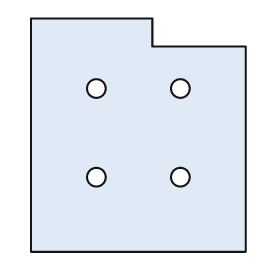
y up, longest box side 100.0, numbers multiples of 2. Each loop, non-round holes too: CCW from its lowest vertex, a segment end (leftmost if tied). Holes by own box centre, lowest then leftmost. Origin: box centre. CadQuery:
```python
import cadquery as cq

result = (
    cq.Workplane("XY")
    .moveTo(-46.0, -50.0)
    .lineTo(46.0, -50.0)
    .lineTo(46.0, 38.0)
    .lineTo(6.0, 38.0)
    .lineTo(6.0, 50.0)
    .lineTo(-46.0, 50.0)
    .close()
    .moveTo(-18.0, -18.0)
    .circle(4.0)
    .moveTo(18.0, -18.0)
    .circle(4.0)
    .moveTo(-18.0, 20.0)
    .circle(4.0)
    .moveTo(18.0, 20.0)
    .circle(4.0)
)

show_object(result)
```